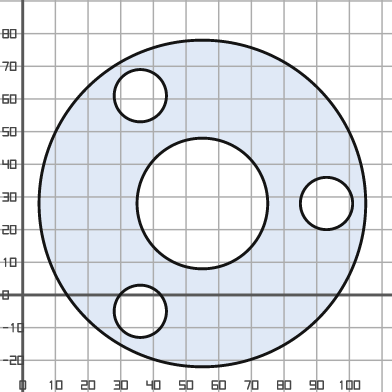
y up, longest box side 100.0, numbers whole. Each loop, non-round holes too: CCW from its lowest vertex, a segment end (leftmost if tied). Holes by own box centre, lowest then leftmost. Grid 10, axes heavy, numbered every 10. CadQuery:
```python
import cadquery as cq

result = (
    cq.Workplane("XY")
    .moveTo(55.0, 28.0)
    .circle(50.0)
    .moveTo(36.0, -5.0)
    .circle(8.0)
    .moveTo(55.0, 28.0)
    .circle(20.0)
    .moveTo(93.0, 28.0)
    .circle(8.0)
    .moveTo(36.0, 61.0)
    .circle(8.0)
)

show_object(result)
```